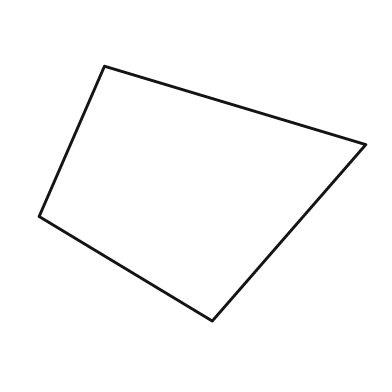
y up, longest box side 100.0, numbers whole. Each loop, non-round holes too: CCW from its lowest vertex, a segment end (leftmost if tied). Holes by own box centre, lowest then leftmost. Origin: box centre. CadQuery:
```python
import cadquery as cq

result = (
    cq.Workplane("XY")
    .moveTo(3.0, -39.0)
    .lineTo(50.0, 15.0)
    .lineTo(-30.0, 39.0)
    .lineTo(-50.0, -7.0)
    .close()
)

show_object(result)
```